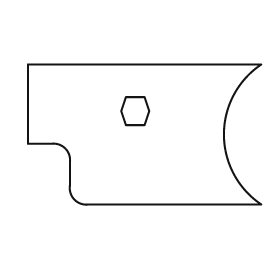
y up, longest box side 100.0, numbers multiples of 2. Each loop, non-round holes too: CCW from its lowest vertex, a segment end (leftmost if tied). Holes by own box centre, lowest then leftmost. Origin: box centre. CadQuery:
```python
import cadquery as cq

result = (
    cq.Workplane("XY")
    .moveTo(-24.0, -30.0)
    .lineTo(50.0, -30.0)
    .threePointArc((34.0, 0.0), (50.0, 30.0))
    .lineTo(-50.0, 30.0)
    .lineTo(-50.0, -4.0)
    .lineTo(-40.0, -4.0)
    .threePointArc((-34.0, -6.0), (-32.0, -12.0))
    .lineTo(-32.0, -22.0)
    .threePointArc((-30.0, -28.0), (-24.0, -30.0))
    .close()
    .moveTo(-8.0, 4.0)
    .lineTo(0.0, 4.0)
    .lineTo(2.0, 10.0)
    .lineTo(0.0, 16.0)
    .lineTo(-8.0, 16.0)
    .lineTo(-10.0, 10.0)
    .close()
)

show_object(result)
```